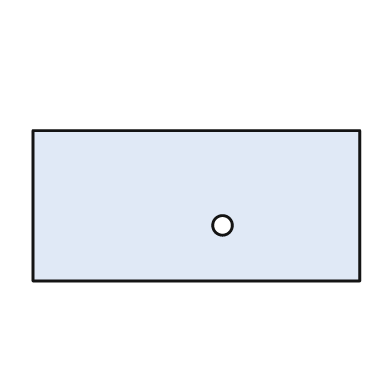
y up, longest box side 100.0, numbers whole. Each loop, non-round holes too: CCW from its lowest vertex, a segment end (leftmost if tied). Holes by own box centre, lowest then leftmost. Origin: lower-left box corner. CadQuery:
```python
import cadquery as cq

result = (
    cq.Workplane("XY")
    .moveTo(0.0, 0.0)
    .lineTo(100.0, 0.0)
    .lineTo(100.0, 46.0)
    .lineTo(0.0, 46.0)
    .close()
    .moveTo(58.0, 17.0)
    .circle(3.0)
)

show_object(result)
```